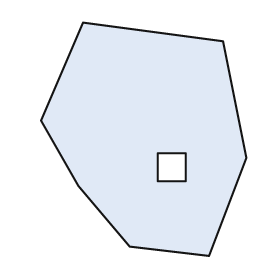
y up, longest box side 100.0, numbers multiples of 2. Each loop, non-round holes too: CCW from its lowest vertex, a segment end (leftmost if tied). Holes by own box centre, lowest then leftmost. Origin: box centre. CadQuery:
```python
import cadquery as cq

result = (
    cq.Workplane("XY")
    .moveTo(28.0, -50.0)
    .lineTo(44.0, -8.0)
    .lineTo(34.0, 42.0)
    .lineTo(-26.0, 50.0)
    .lineTo(-44.0, 8.0)
    .lineTo(-28.0, -20.0)
    .lineTo(-6.0, -46.0)
    .close()
    .moveTo(6.0, -18.0)
    .lineTo(18.0, -18.0)
    .lineTo(18.0, -6.0)
    .lineTo(6.0, -6.0)
    .close()
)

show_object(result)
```